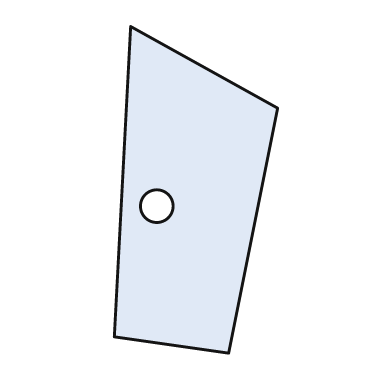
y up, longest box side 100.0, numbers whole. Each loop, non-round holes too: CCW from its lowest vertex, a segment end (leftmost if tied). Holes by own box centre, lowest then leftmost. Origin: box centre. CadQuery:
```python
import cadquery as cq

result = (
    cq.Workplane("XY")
    .moveTo(10.0, -50.0)
    .lineTo(25.0, 25.0)
    .lineTo(-20.0, 50.0)
    .lineTo(-25.0, -45.0)
    .close()
    .moveTo(-12.0, -5.0)
    .circle(5.0)
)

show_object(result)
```